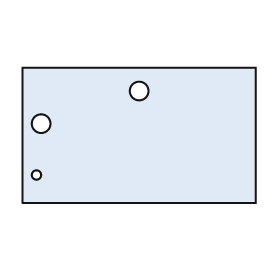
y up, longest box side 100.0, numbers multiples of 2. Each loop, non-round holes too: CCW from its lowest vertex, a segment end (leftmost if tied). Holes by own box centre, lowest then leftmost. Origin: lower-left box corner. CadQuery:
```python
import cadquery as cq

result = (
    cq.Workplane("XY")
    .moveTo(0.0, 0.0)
    .lineTo(100.0, 0.0)
    .lineTo(100.0, 58.0)
    .lineTo(0.0, 58.0)
    .close()
    .moveTo(6.0, 12.0)
    .circle(2.0)
    .moveTo(8.0, 34.0)
    .circle(4.0)
    .moveTo(50.0, 48.0)
    .circle(4.0)
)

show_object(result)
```